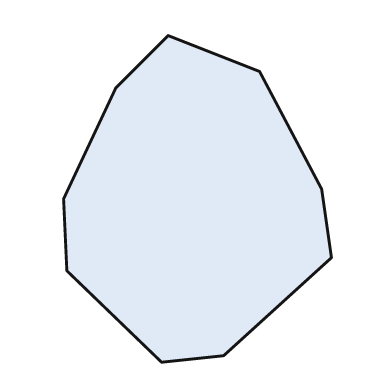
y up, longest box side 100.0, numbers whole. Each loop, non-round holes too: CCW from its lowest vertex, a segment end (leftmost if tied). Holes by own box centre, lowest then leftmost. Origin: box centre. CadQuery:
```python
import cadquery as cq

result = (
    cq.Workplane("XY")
    .moveTo(-11.0, -50.0)
    .lineTo(8.0, -48.0)
    .lineTo(41.0, -18.0)
    .lineTo(38.0, 3.0)
    .lineTo(19.0, 39.0)
    .lineTo(-9.0, 50.0)
    .lineTo(-25.0, 34.0)
    .lineTo(-41.0, 0.0)
    .lineTo(-40.0, -22.0)
    .close()
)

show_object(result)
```